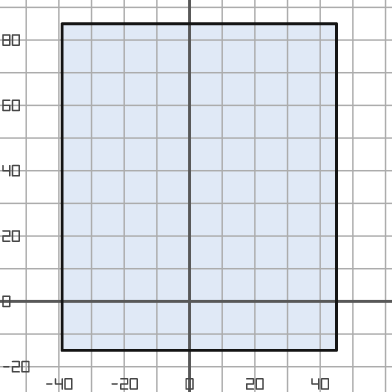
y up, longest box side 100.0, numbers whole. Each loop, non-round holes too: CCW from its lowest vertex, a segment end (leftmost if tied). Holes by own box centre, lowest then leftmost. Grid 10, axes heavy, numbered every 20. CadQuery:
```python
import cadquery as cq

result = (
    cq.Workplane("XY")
    .moveTo(-39.0, -15.0)
    .lineTo(45.0, -15.0)
    .lineTo(45.0, 85.0)
    .lineTo(-39.0, 85.0)
    .close()
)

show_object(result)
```